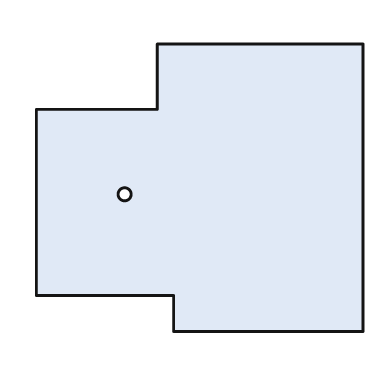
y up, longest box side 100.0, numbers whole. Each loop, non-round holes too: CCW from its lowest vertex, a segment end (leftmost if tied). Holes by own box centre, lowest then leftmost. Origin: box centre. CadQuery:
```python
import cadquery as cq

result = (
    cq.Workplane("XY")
    .moveTo(-8.0, -44.0)
    .lineTo(50.0, -44.0)
    .lineTo(50.0, 44.0)
    .lineTo(-13.0, 44.0)
    .lineTo(-13.0, 24.0)
    .lineTo(-50.0, 24.0)
    .lineTo(-50.0, -33.0)
    .lineTo(-8.0, -33.0)
    .close()
    .moveTo(-23.0, -2.0)
    .circle(2.0)
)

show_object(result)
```